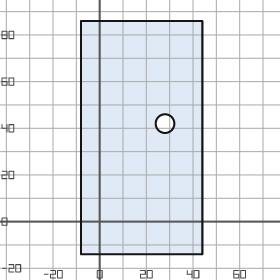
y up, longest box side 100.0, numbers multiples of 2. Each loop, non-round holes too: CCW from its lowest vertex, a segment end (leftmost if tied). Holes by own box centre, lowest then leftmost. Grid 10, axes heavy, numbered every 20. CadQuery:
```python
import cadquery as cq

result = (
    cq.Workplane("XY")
    .moveTo(-8.0, -14.0)
    .lineTo(44.0, -14.0)
    .lineTo(44.0, 86.0)
    .lineTo(-8.0, 86.0)
    .close()
    .moveTo(28.0, 42.0)
    .circle(4.0)
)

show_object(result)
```